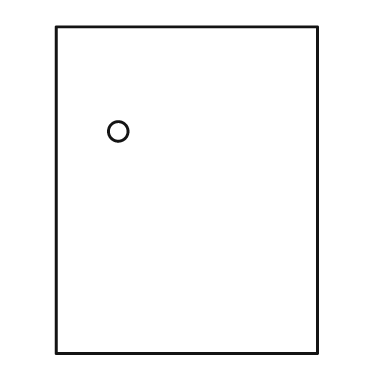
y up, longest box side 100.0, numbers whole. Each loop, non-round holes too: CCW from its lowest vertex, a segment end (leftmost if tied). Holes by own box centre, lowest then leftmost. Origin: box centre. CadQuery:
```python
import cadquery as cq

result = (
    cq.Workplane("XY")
    .moveTo(-40.0, -50.0)
    .lineTo(40.0, -50.0)
    .lineTo(40.0, 50.0)
    .lineTo(-40.0, 50.0)
    .close()
    .moveTo(-21.0, 18.0)
    .circle(3.0)
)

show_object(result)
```